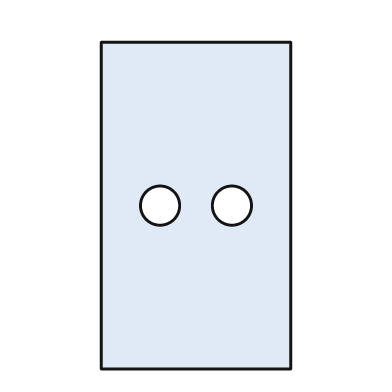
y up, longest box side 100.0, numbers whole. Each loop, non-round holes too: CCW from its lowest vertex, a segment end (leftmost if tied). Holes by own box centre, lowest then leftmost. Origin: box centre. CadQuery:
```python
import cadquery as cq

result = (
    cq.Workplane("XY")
    .moveTo(-29.0, -50.0)
    .lineTo(29.0, -50.0)
    .lineTo(29.0, 50.0)
    .lineTo(-29.0, 50.0)
    .close()
    .moveTo(-11.0, 0.0)
    .circle(6.0)
    .moveTo(11.0, 0.0)
    .circle(6.0)
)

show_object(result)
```